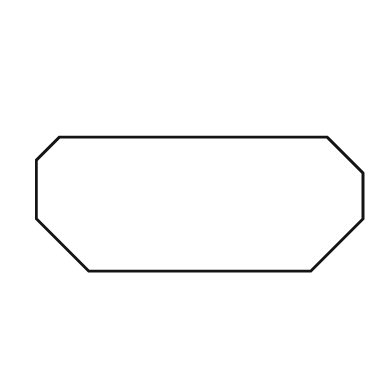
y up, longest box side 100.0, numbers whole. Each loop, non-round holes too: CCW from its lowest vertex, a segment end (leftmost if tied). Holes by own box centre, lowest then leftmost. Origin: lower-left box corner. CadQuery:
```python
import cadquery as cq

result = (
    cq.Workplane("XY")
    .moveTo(16.0, 0.0)
    .lineTo(84.0, 0.0)
    .lineTo(100.0, 16.0)
    .lineTo(100.0, 30.0)
    .lineTo(89.0, 41.0)
    .lineTo(7.0, 41.0)
    .lineTo(0.0, 34.0)
    .lineTo(0.0, 16.0)
    .close()
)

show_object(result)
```